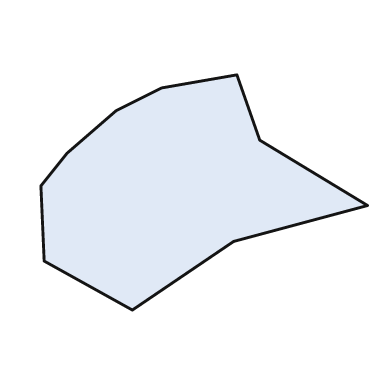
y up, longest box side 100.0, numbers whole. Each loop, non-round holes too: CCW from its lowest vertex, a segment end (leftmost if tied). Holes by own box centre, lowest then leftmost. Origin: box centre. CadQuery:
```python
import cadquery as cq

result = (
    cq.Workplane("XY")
    .moveTo(-22.0, -36.0)
    .lineTo(9.0, -15.0)
    .lineTo(50.0, -4.0)
    .lineTo(17.0, 16.0)
    .lineTo(10.0, 36.0)
    .lineTo(-13.0, 32.0)
    .lineTo(-27.0, 25.0)
    .lineTo(-42.0, 12.0)
    .lineTo(-50.0, 2.0)
    .lineTo(-49.0, -21.0)
    .close()
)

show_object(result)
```